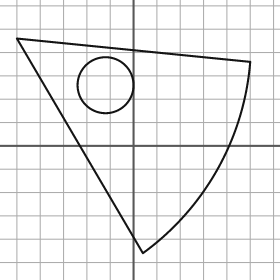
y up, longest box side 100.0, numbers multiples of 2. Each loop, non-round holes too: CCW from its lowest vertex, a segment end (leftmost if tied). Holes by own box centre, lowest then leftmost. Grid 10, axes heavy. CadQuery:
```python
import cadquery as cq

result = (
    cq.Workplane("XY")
    .moveTo(4.0, -46.0)
    .threePointArc((36.0, -10.0), (50.0, 36.0))
    .lineTo(-50.0, 46.0)
    .close()
    .moveTo(-12.0, 26.0)
    .circle(12.0)
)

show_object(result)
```